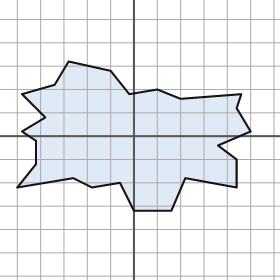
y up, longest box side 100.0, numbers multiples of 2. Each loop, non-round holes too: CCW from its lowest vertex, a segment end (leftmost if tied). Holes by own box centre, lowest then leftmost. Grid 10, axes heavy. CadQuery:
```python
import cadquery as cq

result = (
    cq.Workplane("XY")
    .moveTo(0.0, -32.0)
    .lineTo(16.0, -32.0)
    .lineTo(22.0, -18.0)
    .lineTo(44.0, -22.0)
    .lineTo(44.0, -10.0)
    .lineTo(36.0, -4.0)
    .lineTo(50.0, 2.0)
    .lineTo(44.0, 12.0)
    .lineTo(46.0, 18.0)
    .lineTo(20.0, 16.0)
    .lineTo(10.0, 20.0)
    .lineTo(-2.0, 18.0)
    .lineTo(-10.0, 28.0)
    .lineTo(-28.0, 32.0)
    .lineTo(-34.0, 22.0)
    .lineTo(-48.0, 18.0)
    .lineTo(-38.0, 8.0)
    .lineTo(-48.0, 2.0)
    .lineTo(-42.0, -2.0)
    .lineTo(-42.0, -12.0)
    .lineTo(-50.0, -22.0)
    .lineTo(-26.0, -18.0)
    .lineTo(-18.0, -22.0)
    .lineTo(-6.0, -20.0)
    .close()
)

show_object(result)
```